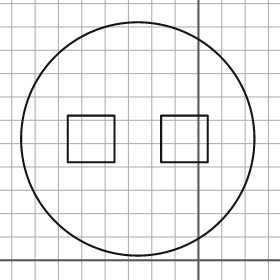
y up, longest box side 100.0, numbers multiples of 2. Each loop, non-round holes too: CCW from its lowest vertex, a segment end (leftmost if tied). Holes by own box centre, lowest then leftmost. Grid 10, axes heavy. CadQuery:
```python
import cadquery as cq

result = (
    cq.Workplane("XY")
    .moveTo(-26.0, 52.0)
    .circle(50.0)
    .moveTo(-56.0, 42.0)
    .lineTo(-36.0, 42.0)
    .lineTo(-36.0, 62.0)
    .lineTo(-56.0, 62.0)
    .close()
    .moveTo(-16.0, 42.0)
    .lineTo(4.0, 42.0)
    .lineTo(4.0, 62.0)
    .lineTo(-16.0, 62.0)
    .close()
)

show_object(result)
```